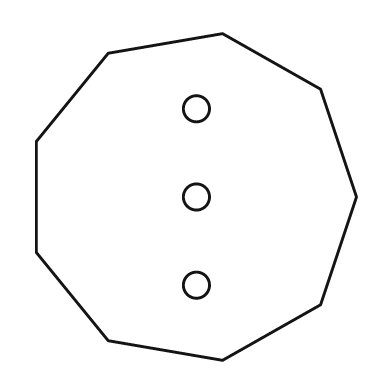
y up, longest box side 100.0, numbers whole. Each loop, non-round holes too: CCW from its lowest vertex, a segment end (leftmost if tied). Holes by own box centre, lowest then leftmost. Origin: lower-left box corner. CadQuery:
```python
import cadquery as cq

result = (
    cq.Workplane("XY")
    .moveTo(57.0, 0.0)
    .lineTo(87.0, 17.0)
    .lineTo(98.0, 50.0)
    .lineTo(87.0, 83.0)
    .lineTo(57.0, 100.0)
    .lineTo(22.0, 94.0)
    .lineTo(0.0, 67.0)
    .lineTo(0.0, 33.0)
    .lineTo(22.0, 6.0)
    .close()
    .moveTo(49.0, 23.0)
    .circle(4.0)
    .moveTo(49.0, 50.0)
    .circle(4.0)
    .moveTo(49.0, 77.0)
    .circle(4.0)
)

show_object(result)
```